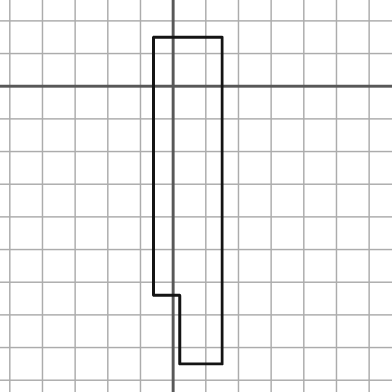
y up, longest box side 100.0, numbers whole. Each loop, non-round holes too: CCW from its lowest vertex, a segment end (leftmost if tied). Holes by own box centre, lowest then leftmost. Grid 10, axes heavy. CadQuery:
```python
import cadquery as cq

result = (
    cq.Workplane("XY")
    .moveTo(2.0, -85.0)
    .lineTo(15.0, -85.0)
    .lineTo(15.0, 15.0)
    .lineTo(-6.0, 15.0)
    .lineTo(-6.0, -64.0)
    .lineTo(2.0, -64.0)
    .close()
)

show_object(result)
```